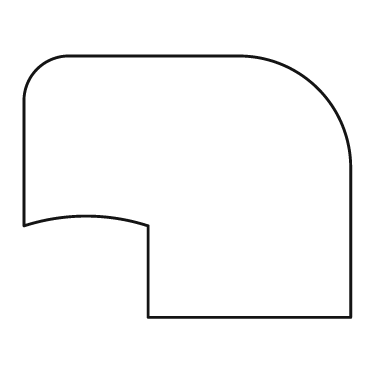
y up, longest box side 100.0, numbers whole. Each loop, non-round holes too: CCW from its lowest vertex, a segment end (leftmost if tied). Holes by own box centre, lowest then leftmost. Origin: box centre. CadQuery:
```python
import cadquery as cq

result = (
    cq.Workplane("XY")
    .moveTo(-12.0, -40.0)
    .lineTo(50.0, -40.0)
    .lineTo(50.0, 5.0)
    .threePointArc((40.0, 30.0), (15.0, 40.0))
    .lineTo(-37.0, 40.0)
    .threePointArc((-46.0, 36.0), (-50.0, 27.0))
    .lineTo(-50.0, -12.0)
    .threePointArc((-31.0, -9.0), (-12.0, -12.0))
    .close()
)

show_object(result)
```